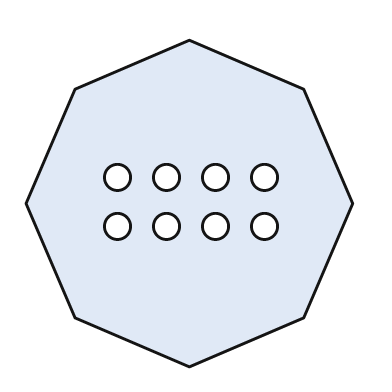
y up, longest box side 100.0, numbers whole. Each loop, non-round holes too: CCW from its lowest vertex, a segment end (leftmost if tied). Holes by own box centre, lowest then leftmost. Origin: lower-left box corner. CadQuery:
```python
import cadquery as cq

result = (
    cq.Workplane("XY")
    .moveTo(50.0, 0.0)
    .lineTo(85.0, 15.0)
    .lineTo(100.0, 50.0)
    .lineTo(85.0, 85.0)
    .lineTo(50.0, 100.0)
    .lineTo(15.0, 85.0)
    .lineTo(0.0, 50.0)
    .lineTo(15.0, 15.0)
    .close()
    .moveTo(28.0, 43.0)
    .circle(4.0)
    .moveTo(43.0, 43.0)
    .circle(4.0)
    .moveTo(58.0, 43.0)
    .circle(4.0)
    .moveTo(73.0, 43.0)
    .circle(4.0)
    .moveTo(28.0, 58.0)
    .circle(4.0)
    .moveTo(43.0, 58.0)
    .circle(4.0)
    .moveTo(58.0, 58.0)
    .circle(4.0)
    .moveTo(73.0, 58.0)
    .circle(4.0)
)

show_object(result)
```